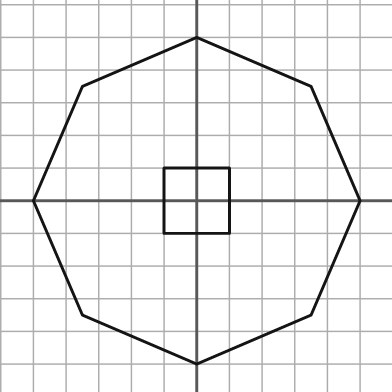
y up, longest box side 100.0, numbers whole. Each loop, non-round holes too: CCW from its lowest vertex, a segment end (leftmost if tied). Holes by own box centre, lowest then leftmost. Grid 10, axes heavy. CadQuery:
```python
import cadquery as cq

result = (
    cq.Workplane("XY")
    .moveTo(0.0, -50.0)
    .lineTo(35.0, -35.0)
    .lineTo(50.0, 0.0)
    .lineTo(35.0, 35.0)
    .lineTo(0.0, 50.0)
    .lineTo(-35.0, 35.0)
    .lineTo(-50.0, 0.0)
    .lineTo(-35.0, -35.0)
    .close()
    .moveTo(-10.0, -10.0)
    .lineTo(10.0, -10.0)
    .lineTo(10.0, 10.0)
    .lineTo(-10.0, 10.0)
    .close()
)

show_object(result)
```